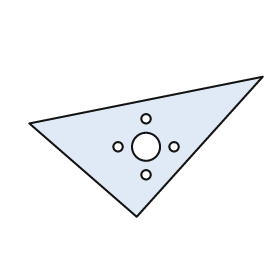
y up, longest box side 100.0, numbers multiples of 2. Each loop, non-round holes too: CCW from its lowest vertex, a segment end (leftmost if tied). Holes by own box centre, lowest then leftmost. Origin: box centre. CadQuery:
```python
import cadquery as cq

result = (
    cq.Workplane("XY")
    .moveTo(-4.0, -30.0)
    .lineTo(50.0, 30.0)
    .lineTo(-50.0, 10.0)
    .close()
    .moveTo(0.0, -12.0)
    .circle(2.0)
    .moveTo(-12.0, 0.0)
    .circle(2.0)
    .moveTo(0.0, 0.0)
    .circle(6.0)
    .moveTo(12.0, 0.0)
    .circle(2.0)
    .moveTo(0.0, 12.0)
    .circle(2.0)
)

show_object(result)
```